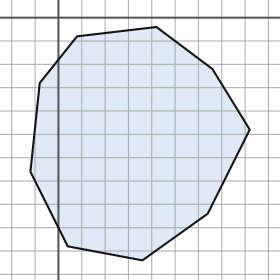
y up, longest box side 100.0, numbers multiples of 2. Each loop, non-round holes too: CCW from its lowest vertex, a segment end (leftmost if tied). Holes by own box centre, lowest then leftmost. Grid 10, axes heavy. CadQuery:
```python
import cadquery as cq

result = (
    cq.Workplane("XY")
    .moveTo(36.0, -104.0)
    .lineTo(64.0, -84.0)
    .lineTo(82.0, -48.0)
    .lineTo(66.0, -22.0)
    .lineTo(42.0, -4.0)
    .lineTo(8.0, -8.0)
    .lineTo(-8.0, -28.0)
    .lineTo(-12.0, -66.0)
    .lineTo(4.0, -98.0)
    .close()
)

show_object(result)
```